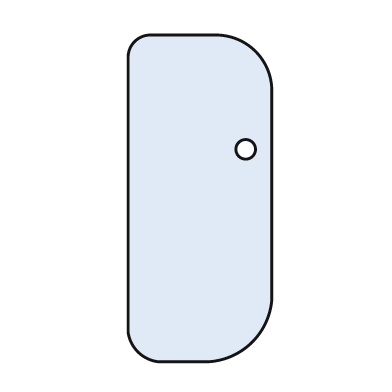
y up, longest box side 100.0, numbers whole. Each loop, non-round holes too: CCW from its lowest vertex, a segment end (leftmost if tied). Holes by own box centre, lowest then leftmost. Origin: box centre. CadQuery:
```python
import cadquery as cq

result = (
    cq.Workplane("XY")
    .moveTo(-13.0, -50.0)
    .lineTo(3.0, -50.0)
    .threePointArc((16.0, -44.0), (22.0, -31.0))
    .lineTo(22.0, 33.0)
    .threePointArc((17.0, 45.0), (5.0, 50.0))
    .lineTo(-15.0, 50.0)
    .threePointArc((-20.0, 48.0), (-22.0, 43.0))
    .lineTo(-22.0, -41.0)
    .threePointArc((-19.0, -47.0), (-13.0, -50.0))
    .close()
    .moveTo(14.0, 15.0)
    .circle(3.0)
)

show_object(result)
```